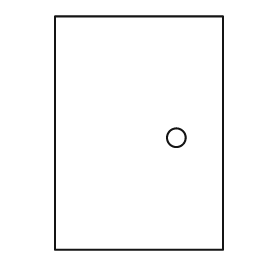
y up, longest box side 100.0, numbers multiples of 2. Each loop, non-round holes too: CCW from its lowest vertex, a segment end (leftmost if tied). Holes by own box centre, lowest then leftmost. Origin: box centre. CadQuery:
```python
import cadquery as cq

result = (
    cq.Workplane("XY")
    .moveTo(-36.0, -50.0)
    .lineTo(36.0, -50.0)
    .lineTo(36.0, 50.0)
    .lineTo(-36.0, 50.0)
    .close()
    .moveTo(16.0, -2.0)
    .circle(4.0)
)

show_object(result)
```